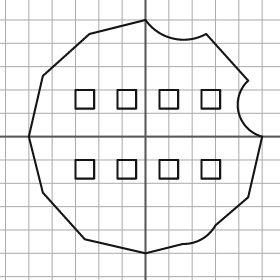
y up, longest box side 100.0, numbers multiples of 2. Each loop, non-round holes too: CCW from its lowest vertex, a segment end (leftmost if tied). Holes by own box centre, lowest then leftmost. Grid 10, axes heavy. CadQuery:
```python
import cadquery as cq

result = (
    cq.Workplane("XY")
    .moveTo(0.0, -50.0)
    .lineTo(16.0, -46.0)
    .threePointArc((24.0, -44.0), (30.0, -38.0))
    .lineTo(44.0, -26.0)
    .lineTo(50.0, 0.0)
    .threePointArc((40.0, 10.0), (44.0, 24.0))
    .lineTo(26.0, 44.0)
    .threePointArc((12.0, 42.0), (0.0, 50.0))
    .lineTo(-24.0, 44.0)
    .lineTo(-44.0, 26.0)
    .lineTo(-50.0, 0.0)
    .lineTo(-44.0, -24.0)
    .lineTo(-26.0, -44.0)
    .close()
    .moveTo(-30.0, -18.0)
    .lineTo(-22.0, -18.0)
    .lineTo(-22.0, -10.0)
    .lineTo(-30.0, -10.0)
    .close()
    .moveTo(-12.0, -18.0)
    .lineTo(-4.0, -18.0)
    .lineTo(-4.0, -10.0)
    .lineTo(-12.0, -10.0)
    .close()
    .moveTo(6.0, -18.0)
    .lineTo(14.0, -18.0)
    .lineTo(14.0, -10.0)
    .lineTo(6.0, -10.0)
    .close()
    .moveTo(24.0, -18.0)
    .lineTo(32.0, -18.0)
    .lineTo(32.0, -10.0)
    .lineTo(24.0, -10.0)
    .close()
    .moveTo(-30.0, 12.0)
    .lineTo(-22.0, 12.0)
    .lineTo(-22.0, 20.0)
    .lineTo(-30.0, 20.0)
    .close()
    .moveTo(-12.0, 12.0)
    .lineTo(-4.0, 12.0)
    .lineTo(-4.0, 20.0)
    .lineTo(-12.0, 20.0)
    .close()
    .moveTo(6.0, 12.0)
    .lineTo(14.0, 12.0)
    .lineTo(14.0, 20.0)
    .lineTo(6.0, 20.0)
    .close()
    .moveTo(24.0, 12.0)
    .lineTo(32.0, 12.0)
    .lineTo(32.0, 20.0)
    .lineTo(24.0, 20.0)
    .close()
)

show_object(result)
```